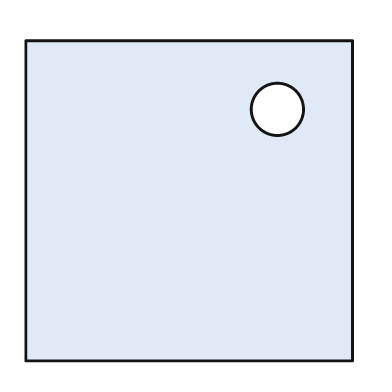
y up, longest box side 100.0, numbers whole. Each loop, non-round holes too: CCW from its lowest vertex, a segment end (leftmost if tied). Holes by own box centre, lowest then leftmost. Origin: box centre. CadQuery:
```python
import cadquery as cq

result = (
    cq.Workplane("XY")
    .moveTo(-50.0, -49.0)
    .lineTo(50.0, -49.0)
    .lineTo(50.0, 49.0)
    .lineTo(-50.0, 49.0)
    .close()
    .moveTo(27.0, 28.0)
    .circle(8.0)
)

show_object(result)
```